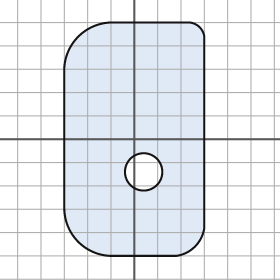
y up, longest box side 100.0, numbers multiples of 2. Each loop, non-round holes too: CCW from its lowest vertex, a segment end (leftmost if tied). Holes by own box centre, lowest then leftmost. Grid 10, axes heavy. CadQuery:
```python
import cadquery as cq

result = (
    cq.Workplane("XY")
    .moveTo(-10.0, -50.0)
    .lineTo(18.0, -50.0)
    .threePointArc((26.0, -46.0), (30.0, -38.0))
    .lineTo(30.0, 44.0)
    .threePointArc((28.0, 48.0), (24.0, 50.0))
    .lineTo(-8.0, 50.0)
    .threePointArc((-24.0, 44.0), (-30.0, 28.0))
    .lineTo(-30.0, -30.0)
    .threePointArc((-24.0, -44.0), (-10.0, -50.0))
    .close()
    .moveTo(4.0, -14.0)
    .circle(8.0)
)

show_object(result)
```